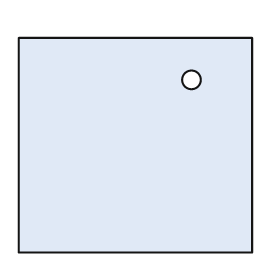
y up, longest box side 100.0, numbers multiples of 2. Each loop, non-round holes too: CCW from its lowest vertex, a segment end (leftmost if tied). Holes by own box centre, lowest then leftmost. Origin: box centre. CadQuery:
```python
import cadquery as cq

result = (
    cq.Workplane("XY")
    .moveTo(-50.0, -46.0)
    .lineTo(50.0, -46.0)
    .lineTo(50.0, 46.0)
    .lineTo(-50.0, 46.0)
    .close()
    .moveTo(24.0, 28.0)
    .circle(4.0)
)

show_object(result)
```